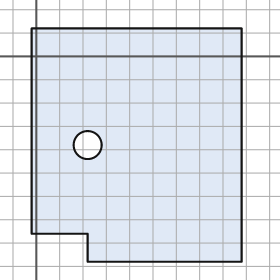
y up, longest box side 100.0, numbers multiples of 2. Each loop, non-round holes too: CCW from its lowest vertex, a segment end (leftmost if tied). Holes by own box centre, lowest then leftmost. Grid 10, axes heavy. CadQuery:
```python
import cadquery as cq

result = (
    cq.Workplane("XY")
    .moveTo(22.0, -88.0)
    .lineTo(88.0, -88.0)
    .lineTo(88.0, 12.0)
    .lineTo(-2.0, 12.0)
    .lineTo(-2.0, -76.0)
    .lineTo(22.0, -76.0)
    .close()
    .moveTo(22.0, -38.0)
    .circle(6.0)
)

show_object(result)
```